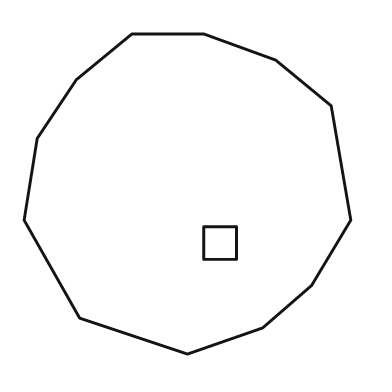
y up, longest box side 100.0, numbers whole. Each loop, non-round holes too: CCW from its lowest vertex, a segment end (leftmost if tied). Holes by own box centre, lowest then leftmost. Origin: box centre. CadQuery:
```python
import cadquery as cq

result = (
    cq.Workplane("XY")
    .moveTo(0.0, -49.0)
    .lineTo(23.0, -41.0)
    .lineTo(38.0, -28.0)
    .lineTo(50.0, -8.0)
    .lineTo(44.0, 27.0)
    .lineTo(27.0, 41.0)
    .lineTo(5.0, 49.0)
    .lineTo(-17.0, 49.0)
    .lineTo(-34.0, 35.0)
    .lineTo(-46.0, 17.0)
    .lineTo(-50.0, -8.0)
    .lineTo(-33.0, -38.0)
    .close()
    .moveTo(5.0, -20.0)
    .lineTo(15.0, -20.0)
    .lineTo(15.0, -10.0)
    .lineTo(5.0, -10.0)
    .close()
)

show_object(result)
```